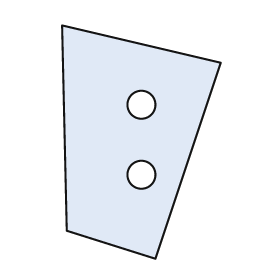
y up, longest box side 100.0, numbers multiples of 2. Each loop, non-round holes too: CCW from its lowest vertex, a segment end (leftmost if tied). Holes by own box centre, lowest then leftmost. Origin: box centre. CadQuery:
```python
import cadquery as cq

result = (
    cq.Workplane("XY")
    .moveTo(6.0, -50.0)
    .lineTo(34.0, 34.0)
    .lineTo(-34.0, 50.0)
    .lineTo(-32.0, -38.0)
    .close()
    .moveTo(0.0, -14.0)
    .circle(6.0)
    .moveTo(0.0, 16.0)
    .circle(6.0)
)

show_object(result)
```